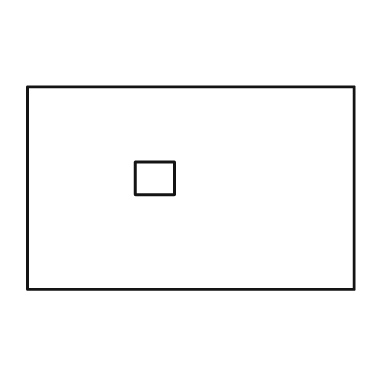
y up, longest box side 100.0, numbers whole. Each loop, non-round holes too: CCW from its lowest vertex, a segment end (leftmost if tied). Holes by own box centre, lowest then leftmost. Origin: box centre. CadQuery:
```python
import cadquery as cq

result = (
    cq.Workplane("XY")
    .moveTo(-50.0, -31.0)
    .lineTo(50.0, -31.0)
    .lineTo(50.0, 31.0)
    .lineTo(-50.0, 31.0)
    .close()
    .moveTo(-17.0, -2.0)
    .lineTo(-5.0, -2.0)
    .lineTo(-5.0, 8.0)
    .lineTo(-17.0, 8.0)
    .close()
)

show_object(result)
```